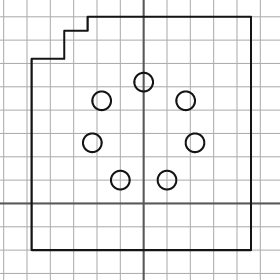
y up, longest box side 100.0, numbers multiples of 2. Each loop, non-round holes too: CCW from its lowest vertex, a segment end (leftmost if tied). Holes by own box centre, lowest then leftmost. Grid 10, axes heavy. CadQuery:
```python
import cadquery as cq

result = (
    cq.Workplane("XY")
    .moveTo(-48.0, -20.0)
    .lineTo(46.0, -20.0)
    .lineTo(46.0, 80.0)
    .lineTo(-24.0, 80.0)
    .lineTo(-24.0, 74.0)
    .lineTo(-34.0, 74.0)
    .lineTo(-34.0, 62.0)
    .lineTo(-48.0, 62.0)
    .close()
    .moveTo(-10.0, 10.0)
    .circle(4.0)
    .moveTo(10.0, 10.0)
    .circle(4.0)
    .moveTo(-22.0, 26.0)
    .circle(4.0)
    .moveTo(22.0, 26.0)
    .circle(4.0)
    .moveTo(-18.0, 44.0)
    .circle(4.0)
    .moveTo(18.0, 44.0)
    .circle(4.0)
    .moveTo(0.0, 52.0)
    .circle(4.0)
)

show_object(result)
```